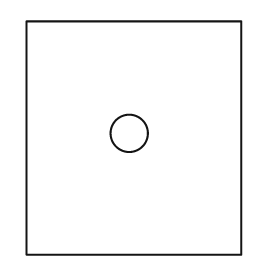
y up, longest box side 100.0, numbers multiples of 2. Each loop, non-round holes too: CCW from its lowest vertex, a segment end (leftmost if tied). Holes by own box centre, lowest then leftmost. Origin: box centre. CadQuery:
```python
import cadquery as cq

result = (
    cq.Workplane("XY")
    .moveTo(-46.0, -50.0)
    .lineTo(46.0, -50.0)
    .lineTo(46.0, 50.0)
    .lineTo(-46.0, 50.0)
    .close()
    .moveTo(-2.0, 2.0)
    .circle(8.0)
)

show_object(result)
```